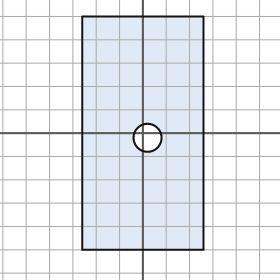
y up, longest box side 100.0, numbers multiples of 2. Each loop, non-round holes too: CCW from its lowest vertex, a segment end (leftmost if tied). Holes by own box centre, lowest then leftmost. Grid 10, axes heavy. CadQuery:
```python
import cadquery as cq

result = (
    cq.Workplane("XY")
    .moveTo(-26.0, -50.0)
    .lineTo(26.0, -50.0)
    .lineTo(26.0, 50.0)
    .lineTo(-26.0, 50.0)
    .close()
    .moveTo(2.0, -2.0)
    .circle(6.0)
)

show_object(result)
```